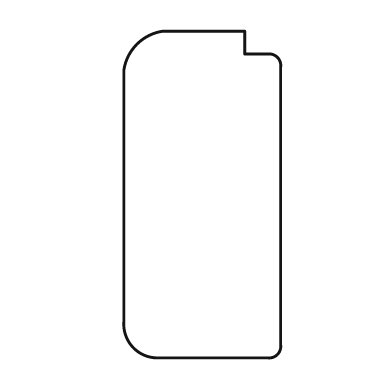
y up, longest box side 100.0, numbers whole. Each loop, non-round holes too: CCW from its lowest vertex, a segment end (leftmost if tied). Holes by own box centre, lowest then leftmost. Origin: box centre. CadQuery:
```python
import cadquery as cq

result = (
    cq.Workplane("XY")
    .moveTo(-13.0, -50.0)
    .lineTo(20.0, -50.0)
    .threePointArc((23.0, -49.0), (24.0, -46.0))
    .lineTo(24.0, 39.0)
    .threePointArc((23.0, 42.0), (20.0, 43.0))
    .lineTo(13.0, 43.0)
    .lineTo(13.0, 50.0)
    .lineTo(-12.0, 50.0)
    .threePointArc((-20.0, 46.0), (-24.0, 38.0))
    .lineTo(-24.0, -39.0)
    .threePointArc((-21.0, -47.0), (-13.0, -50.0))
    .close()
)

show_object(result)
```